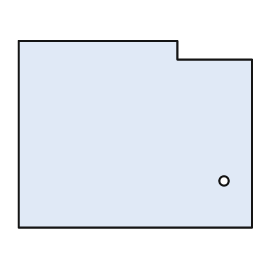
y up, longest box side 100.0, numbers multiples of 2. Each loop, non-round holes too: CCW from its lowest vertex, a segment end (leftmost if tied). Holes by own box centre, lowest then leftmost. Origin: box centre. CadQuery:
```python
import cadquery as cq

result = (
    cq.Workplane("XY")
    .moveTo(-50.0, -40.0)
    .lineTo(50.0, -40.0)
    .lineTo(50.0, 32.0)
    .lineTo(18.0, 32.0)
    .lineTo(18.0, 40.0)
    .lineTo(-50.0, 40.0)
    .close()
    .moveTo(38.0, -20.0)
    .circle(2.0)
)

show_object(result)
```